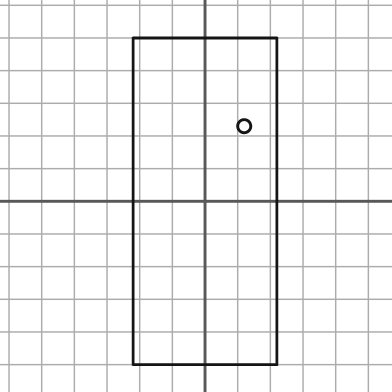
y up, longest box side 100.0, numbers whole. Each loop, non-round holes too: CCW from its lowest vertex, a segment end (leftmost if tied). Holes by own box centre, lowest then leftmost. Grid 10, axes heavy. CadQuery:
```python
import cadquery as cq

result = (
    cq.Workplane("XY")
    .moveTo(-22.0, -50.0)
    .lineTo(22.0, -50.0)
    .lineTo(22.0, 50.0)
    .lineTo(-22.0, 50.0)
    .close()
    .moveTo(12.0, 23.0)
    .circle(2.0)
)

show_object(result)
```